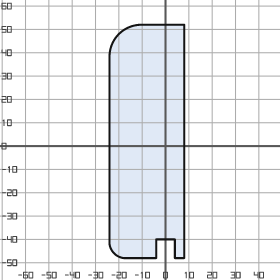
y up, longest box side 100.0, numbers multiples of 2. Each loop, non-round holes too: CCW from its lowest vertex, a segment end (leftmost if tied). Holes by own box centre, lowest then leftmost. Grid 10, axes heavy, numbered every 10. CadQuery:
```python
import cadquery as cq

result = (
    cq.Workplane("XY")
    .moveTo(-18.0, -48.0)
    .lineTo(-4.0, -48.0)
    .lineTo(-4.0, -40.0)
    .lineTo(4.0, -40.0)
    .lineTo(4.0, -48.0)
    .lineTo(8.0, -48.0)
    .lineTo(8.0, 52.0)
    .lineTo(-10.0, 52.0)
    .threePointArc((-20.0, 48.0), (-24.0, 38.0))
    .lineTo(-24.0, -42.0)
    .threePointArc((-22.0, -46.0), (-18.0, -48.0))
    .close()
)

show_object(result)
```